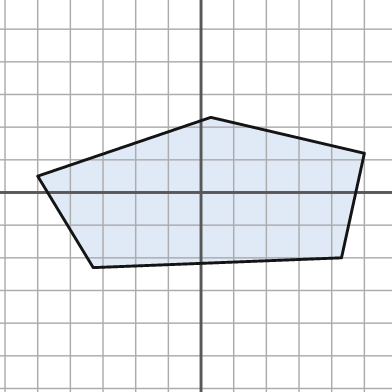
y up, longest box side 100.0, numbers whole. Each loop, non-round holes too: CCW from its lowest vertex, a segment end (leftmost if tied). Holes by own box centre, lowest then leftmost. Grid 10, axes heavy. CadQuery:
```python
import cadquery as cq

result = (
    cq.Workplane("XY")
    .moveTo(-33.0, -23.0)
    .lineTo(43.0, -20.0)
    .lineTo(50.0, 12.0)
    .lineTo(3.0, 23.0)
    .lineTo(-50.0, 5.0)
    .close()
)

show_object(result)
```